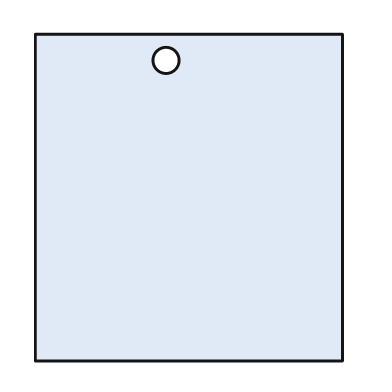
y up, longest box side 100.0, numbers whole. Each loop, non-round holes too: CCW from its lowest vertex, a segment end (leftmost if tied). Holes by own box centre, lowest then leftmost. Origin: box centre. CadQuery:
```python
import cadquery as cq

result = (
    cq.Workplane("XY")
    .moveTo(-47.0, -50.0)
    .lineTo(47.0, -50.0)
    .lineTo(47.0, 50.0)
    .lineTo(-47.0, 50.0)
    .close()
    .moveTo(-7.0, 42.0)
    .circle(4.0)
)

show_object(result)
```